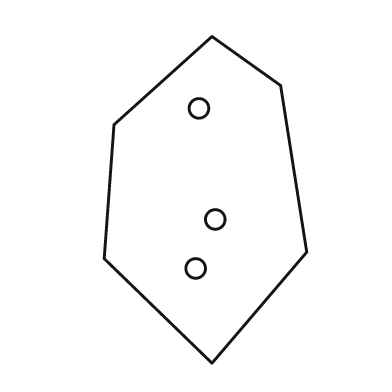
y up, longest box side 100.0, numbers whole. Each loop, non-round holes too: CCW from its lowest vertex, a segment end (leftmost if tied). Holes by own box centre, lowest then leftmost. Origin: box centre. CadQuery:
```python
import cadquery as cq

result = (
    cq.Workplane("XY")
    .moveTo(2.0, -50.0)
    .lineTo(31.0, -16.0)
    .lineTo(23.0, 35.0)
    .lineTo(2.0, 50.0)
    .lineTo(-28.0, 23.0)
    .lineTo(-31.0, -18.0)
    .close()
    .moveTo(-3.0, -21.0)
    .circle(3.0)
    .moveTo(3.0, -6.0)
    .circle(3.0)
    .moveTo(-2.0, 28.0)
    .circle(3.0)
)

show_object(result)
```